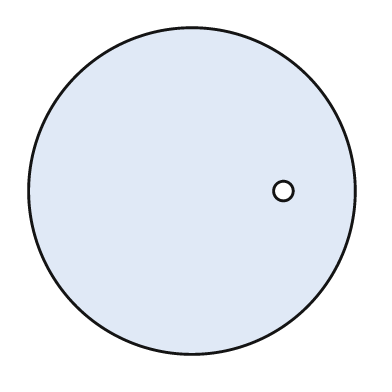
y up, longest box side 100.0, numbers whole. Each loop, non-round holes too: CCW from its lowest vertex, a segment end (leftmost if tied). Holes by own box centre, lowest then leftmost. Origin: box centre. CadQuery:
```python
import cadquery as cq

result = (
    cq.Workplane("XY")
    .moveTo(0.0, 0.0)
    .circle(50.0)
    .moveTo(28.0, 0.0)
    .circle(3.0)
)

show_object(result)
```